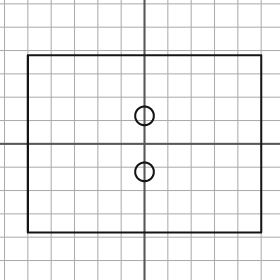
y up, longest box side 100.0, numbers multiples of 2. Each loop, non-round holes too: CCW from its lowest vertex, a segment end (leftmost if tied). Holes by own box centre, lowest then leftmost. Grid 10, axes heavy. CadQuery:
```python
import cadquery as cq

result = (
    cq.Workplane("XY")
    .moveTo(-50.0, -38.0)
    .lineTo(50.0, -38.0)
    .lineTo(50.0, 38.0)
    .lineTo(-50.0, 38.0)
    .close()
    .moveTo(0.0, -12.0)
    .circle(4.0)
    .moveTo(0.0, 12.0)
    .circle(4.0)
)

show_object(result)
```